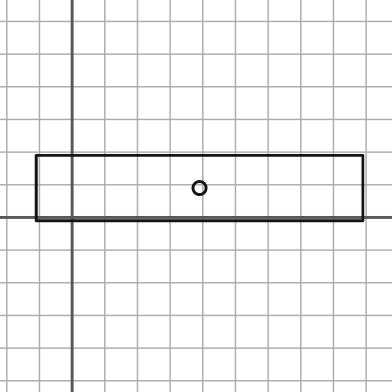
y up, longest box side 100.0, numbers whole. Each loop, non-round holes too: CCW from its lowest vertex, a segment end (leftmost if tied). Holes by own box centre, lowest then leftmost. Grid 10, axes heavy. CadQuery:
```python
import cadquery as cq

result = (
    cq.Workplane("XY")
    .moveTo(-11.0, -1.0)
    .lineTo(89.0, -1.0)
    .lineTo(89.0, 19.0)
    .lineTo(-11.0, 19.0)
    .close()
    .moveTo(39.0, 9.0)
    .circle(2.0)
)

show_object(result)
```